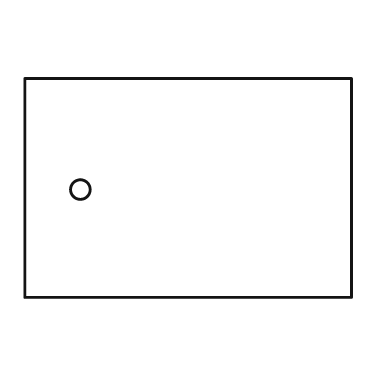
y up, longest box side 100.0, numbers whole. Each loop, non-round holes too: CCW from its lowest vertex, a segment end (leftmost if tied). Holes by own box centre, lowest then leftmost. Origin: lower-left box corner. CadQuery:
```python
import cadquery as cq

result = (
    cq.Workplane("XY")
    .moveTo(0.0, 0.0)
    .lineTo(100.0, 0.0)
    .lineTo(100.0, 67.0)
    .lineTo(0.0, 67.0)
    .close()
    .moveTo(17.0, 33.0)
    .circle(3.0)
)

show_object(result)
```